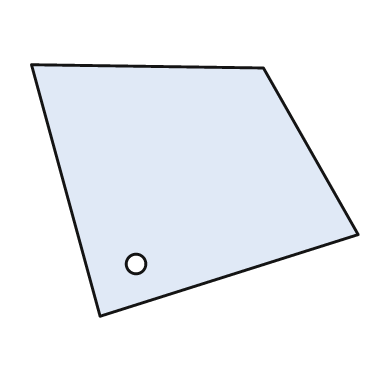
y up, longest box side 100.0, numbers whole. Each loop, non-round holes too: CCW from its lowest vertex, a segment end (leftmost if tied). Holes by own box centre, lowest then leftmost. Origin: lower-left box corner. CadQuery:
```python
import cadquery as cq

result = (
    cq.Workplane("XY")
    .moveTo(21.0, 0.0)
    .lineTo(100.0, 25.0)
    .lineTo(71.0, 76.0)
    .lineTo(0.0, 77.0)
    .close()
    .moveTo(32.0, 16.0)
    .circle(3.0)
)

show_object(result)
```